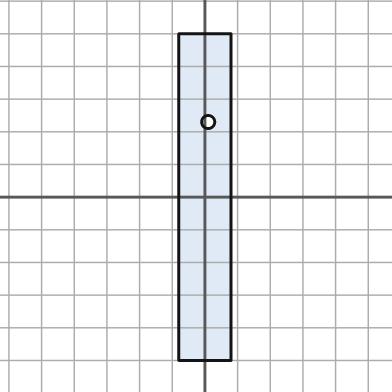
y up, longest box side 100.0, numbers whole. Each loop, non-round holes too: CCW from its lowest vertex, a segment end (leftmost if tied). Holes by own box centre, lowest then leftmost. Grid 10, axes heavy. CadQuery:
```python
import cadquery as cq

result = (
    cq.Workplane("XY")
    .moveTo(-8.0, -50.0)
    .lineTo(8.0, -50.0)
    .lineTo(8.0, 50.0)
    .lineTo(-8.0, 50.0)
    .close()
    .moveTo(1.0, 23.0)
    .circle(2.0)
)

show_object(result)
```